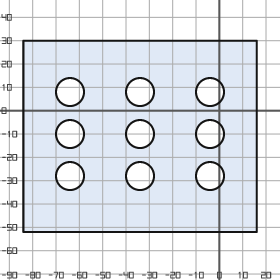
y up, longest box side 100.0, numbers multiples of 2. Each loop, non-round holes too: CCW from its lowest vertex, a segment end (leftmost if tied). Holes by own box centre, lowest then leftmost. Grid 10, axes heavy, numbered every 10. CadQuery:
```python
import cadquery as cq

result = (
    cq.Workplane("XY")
    .moveTo(-84.0, -52.0)
    .lineTo(16.0, -52.0)
    .lineTo(16.0, 30.0)
    .lineTo(-84.0, 30.0)
    .close()
    .moveTo(-64.0, -28.0)
    .circle(6.0)
    .moveTo(-34.0, -28.0)
    .circle(6.0)
    .moveTo(-4.0, -28.0)
    .circle(6.0)
    .moveTo(-64.0, -10.0)
    .circle(6.0)
    .moveTo(-34.0, -10.0)
    .circle(6.0)
    .moveTo(-4.0, -10.0)
    .circle(6.0)
    .moveTo(-64.0, 8.0)
    .circle(6.0)
    .moveTo(-34.0, 8.0)
    .circle(6.0)
    .moveTo(-4.0, 8.0)
    .circle(6.0)
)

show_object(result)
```